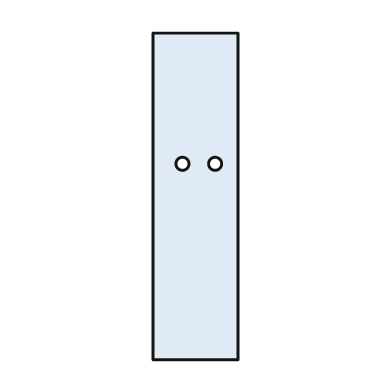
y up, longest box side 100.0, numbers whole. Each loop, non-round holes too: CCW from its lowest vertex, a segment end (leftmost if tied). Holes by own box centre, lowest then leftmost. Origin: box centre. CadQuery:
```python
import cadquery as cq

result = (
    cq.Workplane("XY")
    .moveTo(-13.0, -50.0)
    .lineTo(13.0, -50.0)
    .lineTo(13.0, 50.0)
    .lineTo(-13.0, 50.0)
    .close()
    .moveTo(-4.0, 10.0)
    .circle(2.0)
    .moveTo(6.0, 10.0)
    .circle(2.0)
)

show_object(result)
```